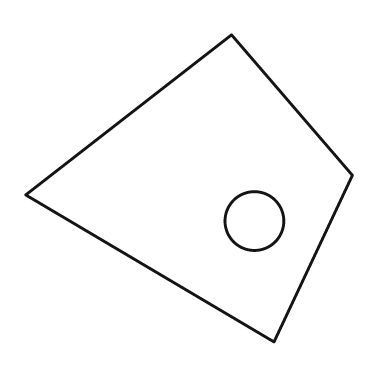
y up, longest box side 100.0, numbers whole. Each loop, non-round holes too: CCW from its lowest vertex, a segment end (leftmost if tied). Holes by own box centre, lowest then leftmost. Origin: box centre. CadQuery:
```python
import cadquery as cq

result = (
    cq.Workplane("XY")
    .moveTo(26.0, -47.0)
    .lineTo(50.0, 4.0)
    .lineTo(13.0, 47.0)
    .lineTo(-50.0, -2.0)
    .close()
    .moveTo(20.0, -10.0)
    .circle(9.0)
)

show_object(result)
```